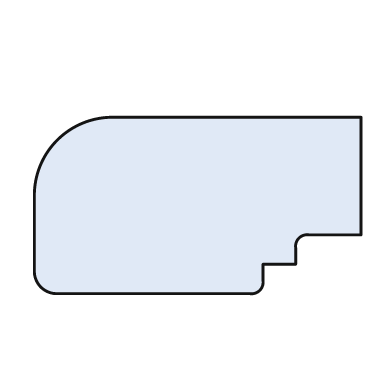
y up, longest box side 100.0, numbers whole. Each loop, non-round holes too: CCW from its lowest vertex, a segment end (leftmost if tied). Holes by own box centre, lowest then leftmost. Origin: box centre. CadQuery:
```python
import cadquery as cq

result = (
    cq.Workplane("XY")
    .moveTo(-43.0, -27.0)
    .lineTo(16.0, -27.0)
    .threePointArc((19.0, -26.0), (20.0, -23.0))
    .lineTo(20.0, -18.0)
    .lineTo(30.0, -18.0)
    .lineTo(30.0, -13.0)
    .threePointArc((31.0, -10.0), (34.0, -9.0))
    .lineTo(50.0, -9.0)
    .lineTo(50.0, 27.0)
    .lineTo(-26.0, 27.0)
    .threePointArc((-43.0, 20.0), (-50.0, 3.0))
    .lineTo(-50.0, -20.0)
    .threePointArc((-48.0, -25.0), (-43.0, -27.0))
    .close()
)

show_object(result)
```